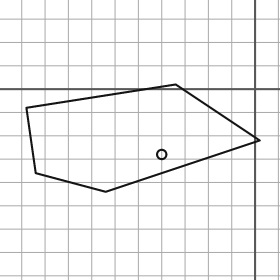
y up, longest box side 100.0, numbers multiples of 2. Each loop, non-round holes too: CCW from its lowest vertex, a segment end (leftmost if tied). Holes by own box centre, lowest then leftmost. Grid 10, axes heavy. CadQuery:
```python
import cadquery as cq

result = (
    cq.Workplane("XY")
    .moveTo(-64.0, -44.0)
    .lineTo(2.0, -22.0)
    .lineTo(-34.0, 2.0)
    .lineTo(-98.0, -8.0)
    .lineTo(-94.0, -36.0)
    .close()
    .moveTo(-40.0, -28.0)
    .circle(2.0)
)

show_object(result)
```